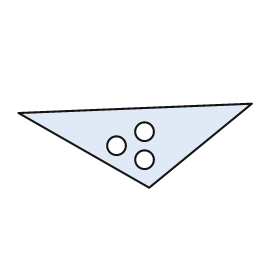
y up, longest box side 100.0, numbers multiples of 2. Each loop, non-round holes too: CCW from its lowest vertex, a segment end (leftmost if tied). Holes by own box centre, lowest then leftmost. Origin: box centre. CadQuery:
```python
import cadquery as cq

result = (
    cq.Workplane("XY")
    .moveTo(6.0, -18.0)
    .lineTo(50.0, 18.0)
    .lineTo(-50.0, 14.0)
    .close()
    .moveTo(4.0, -6.0)
    .circle(4.0)
    .moveTo(-8.0, 0.0)
    .circle(4.0)
    .moveTo(4.0, 6.0)
    .circle(4.0)
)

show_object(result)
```